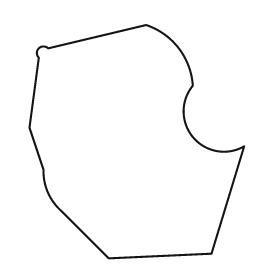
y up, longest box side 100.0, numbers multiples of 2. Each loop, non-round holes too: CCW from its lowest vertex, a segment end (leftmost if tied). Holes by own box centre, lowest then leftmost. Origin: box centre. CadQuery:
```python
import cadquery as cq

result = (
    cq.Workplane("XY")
    .moveTo(-12.0, -50.0)
    .lineTo(32.0, -48.0)
    .lineTo(46.0, -2.0)
    .threePointArc((24.0, 2.0), (24.0, 24.0))
    .threePointArc((18.0, 40.0), (4.0, 50.0))
    .lineTo(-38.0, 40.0)
    .threePointArc((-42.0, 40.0), (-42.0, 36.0))
    .lineTo(-46.0, 6.0)
    .lineTo(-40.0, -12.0)
    .threePointArc((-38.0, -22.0), (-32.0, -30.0))
    .close()
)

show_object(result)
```